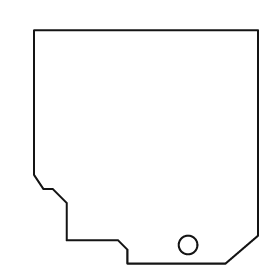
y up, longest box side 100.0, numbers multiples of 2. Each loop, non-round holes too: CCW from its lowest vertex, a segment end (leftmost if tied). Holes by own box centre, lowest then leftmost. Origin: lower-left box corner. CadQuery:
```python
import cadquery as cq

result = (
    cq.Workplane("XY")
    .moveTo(40.0, 0.0)
    .lineTo(82.0, 0.0)
    .lineTo(96.0, 12.0)
    .lineTo(96.0, 100.0)
    .lineTo(0.0, 100.0)
    .lineTo(0.0, 38.0)
    .lineTo(4.0, 32.0)
    .lineTo(8.0, 32.0)
    .lineTo(14.0, 26.0)
    .lineTo(14.0, 10.0)
    .lineTo(36.0, 10.0)
    .lineTo(40.0, 6.0)
    .close()
    .moveTo(66.0, 8.0)
    .circle(4.0)
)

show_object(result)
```